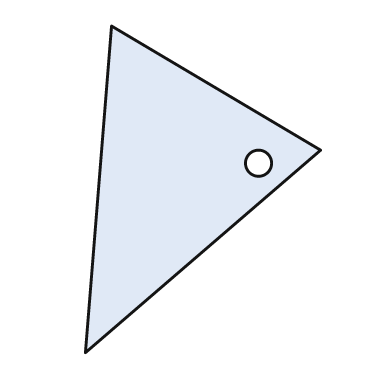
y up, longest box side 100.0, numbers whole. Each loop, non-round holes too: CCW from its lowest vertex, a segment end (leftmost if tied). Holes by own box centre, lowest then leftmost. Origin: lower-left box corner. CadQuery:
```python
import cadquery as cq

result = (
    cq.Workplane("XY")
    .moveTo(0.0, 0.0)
    .lineTo(72.0, 62.0)
    .lineTo(8.0, 100.0)
    .close()
    .moveTo(53.0, 58.0)
    .circle(4.0)
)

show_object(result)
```